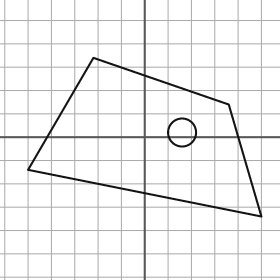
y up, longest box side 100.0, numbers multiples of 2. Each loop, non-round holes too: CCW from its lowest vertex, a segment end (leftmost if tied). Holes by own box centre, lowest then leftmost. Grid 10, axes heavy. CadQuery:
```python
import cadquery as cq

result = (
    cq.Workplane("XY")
    .moveTo(50.0, -34.0)
    .lineTo(36.0, 14.0)
    .lineTo(-22.0, 34.0)
    .lineTo(-50.0, -14.0)
    .close()
    .moveTo(16.0, 2.0)
    .circle(6.0)
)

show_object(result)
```